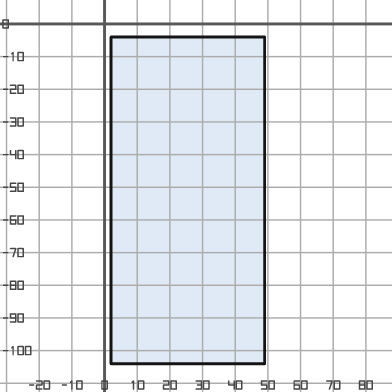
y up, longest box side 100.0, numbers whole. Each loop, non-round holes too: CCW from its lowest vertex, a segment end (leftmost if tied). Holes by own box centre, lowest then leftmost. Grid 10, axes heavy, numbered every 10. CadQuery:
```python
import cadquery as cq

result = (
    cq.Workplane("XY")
    .moveTo(2.0, -104.0)
    .lineTo(49.0, -104.0)
    .lineTo(49.0, -4.0)
    .lineTo(2.0, -4.0)
    .close()
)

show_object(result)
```